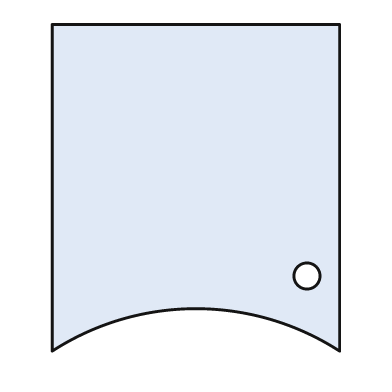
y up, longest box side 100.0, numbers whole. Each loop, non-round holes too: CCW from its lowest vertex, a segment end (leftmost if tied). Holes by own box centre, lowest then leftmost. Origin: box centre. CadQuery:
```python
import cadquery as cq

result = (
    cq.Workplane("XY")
    .moveTo(-44.0, -50.0)
    .threePointArc((0.0, -37.0), (44.0, -50.0))
    .lineTo(44.0, 50.0)
    .lineTo(-44.0, 50.0)
    .close()
    .moveTo(34.0, -27.0)
    .circle(4.0)
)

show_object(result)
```